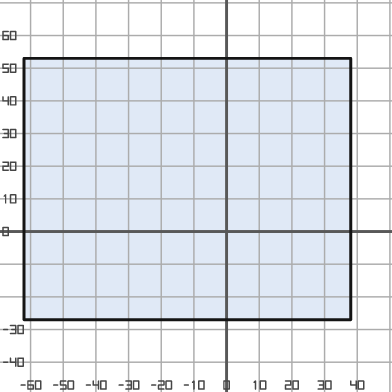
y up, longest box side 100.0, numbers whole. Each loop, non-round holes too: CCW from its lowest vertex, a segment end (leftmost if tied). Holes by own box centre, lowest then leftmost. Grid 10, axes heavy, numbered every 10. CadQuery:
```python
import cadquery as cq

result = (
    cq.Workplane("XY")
    .moveTo(-62.0, -27.0)
    .lineTo(38.0, -27.0)
    .lineTo(38.0, 53.0)
    .lineTo(-62.0, 53.0)
    .close()
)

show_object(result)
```